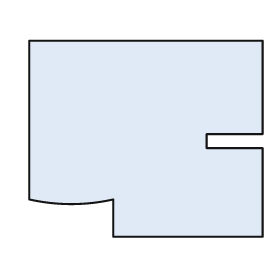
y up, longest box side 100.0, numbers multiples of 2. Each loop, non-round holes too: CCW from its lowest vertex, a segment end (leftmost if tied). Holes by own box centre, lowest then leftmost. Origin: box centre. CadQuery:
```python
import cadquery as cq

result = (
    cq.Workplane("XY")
    .moveTo(-14.0, -42.0)
    .lineTo(50.0, -42.0)
    .lineTo(50.0, -4.0)
    .lineTo(26.0, -4.0)
    .lineTo(26.0, 2.0)
    .lineTo(50.0, 2.0)
    .lineTo(50.0, 42.0)
    .lineTo(-50.0, 42.0)
    .lineTo(-50.0, -26.0)
    .threePointArc((-32.0, -28.0), (-14.0, -26.0))
    .close()
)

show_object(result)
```